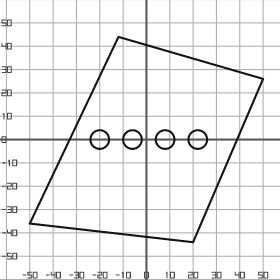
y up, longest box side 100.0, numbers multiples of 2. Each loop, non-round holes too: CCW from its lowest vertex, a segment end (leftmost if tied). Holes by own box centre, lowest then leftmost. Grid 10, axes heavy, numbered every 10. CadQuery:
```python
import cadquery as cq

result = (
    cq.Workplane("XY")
    .moveTo(20.0, -44.0)
    .lineTo(50.0, 26.0)
    .lineTo(-12.0, 44.0)
    .lineTo(-50.0, -36.0)
    .close()
    .moveTo(-20.0, 0.0)
    .circle(4.0)
    .moveTo(-6.0, 0.0)
    .circle(4.0)
    .moveTo(8.0, 0.0)
    .circle(4.0)
    .moveTo(22.0, 0.0)
    .circle(4.0)
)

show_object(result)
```